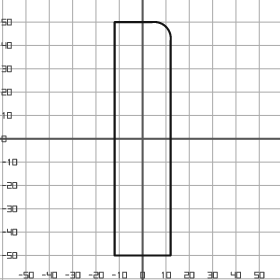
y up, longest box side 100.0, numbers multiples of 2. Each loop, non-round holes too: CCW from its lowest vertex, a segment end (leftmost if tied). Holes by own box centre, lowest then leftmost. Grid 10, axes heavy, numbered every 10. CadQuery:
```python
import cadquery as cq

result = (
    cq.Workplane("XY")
    .moveTo(-12.0, -50.0)
    .lineTo(12.0, -50.0)
    .lineTo(12.0, 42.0)
    .threePointArc((10.0, 48.0), (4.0, 50.0))
    .lineTo(-12.0, 50.0)
    .close()
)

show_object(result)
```